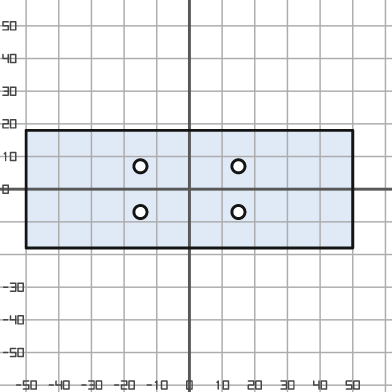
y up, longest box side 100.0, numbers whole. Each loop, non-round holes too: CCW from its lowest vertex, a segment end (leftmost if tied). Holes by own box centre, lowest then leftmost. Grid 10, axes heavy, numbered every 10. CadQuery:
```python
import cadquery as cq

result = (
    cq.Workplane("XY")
    .moveTo(-50.0, -18.0)
    .lineTo(50.0, -18.0)
    .lineTo(50.0, 18.0)
    .lineTo(-50.0, 18.0)
    .close()
    .moveTo(-15.0, -7.0)
    .circle(2.0)
    .moveTo(15.0, -7.0)
    .circle(2.0)
    .moveTo(-15.0, 7.0)
    .circle(2.0)
    .moveTo(15.0, 7.0)
    .circle(2.0)
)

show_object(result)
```